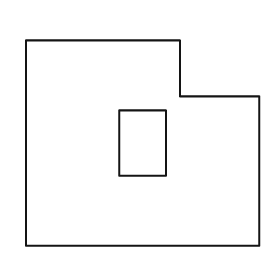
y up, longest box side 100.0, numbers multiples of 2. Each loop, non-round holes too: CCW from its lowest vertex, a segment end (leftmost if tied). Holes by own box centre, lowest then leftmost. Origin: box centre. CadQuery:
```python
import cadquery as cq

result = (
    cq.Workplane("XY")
    .moveTo(-50.0, -44.0)
    .lineTo(50.0, -44.0)
    .lineTo(50.0, 20.0)
    .lineTo(16.0, 20.0)
    .lineTo(16.0, 44.0)
    .lineTo(-50.0, 44.0)
    .close()
    .moveTo(-10.0, -14.0)
    .lineTo(10.0, -14.0)
    .lineTo(10.0, 14.0)
    .lineTo(-10.0, 14.0)
    .close()
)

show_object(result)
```